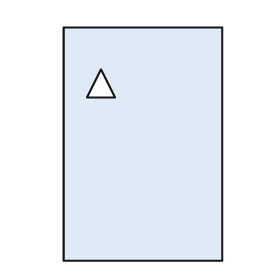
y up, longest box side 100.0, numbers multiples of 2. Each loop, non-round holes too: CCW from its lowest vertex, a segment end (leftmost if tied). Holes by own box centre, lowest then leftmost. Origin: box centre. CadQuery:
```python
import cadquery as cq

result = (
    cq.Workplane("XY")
    .moveTo(-34.0, -50.0)
    .lineTo(34.0, -50.0)
    .lineTo(34.0, 50.0)
    .lineTo(-34.0, 50.0)
    .close()
    .moveTo(-24.0, 20.0)
    .lineTo(-12.0, 20.0)
    .lineTo(-18.0, 32.0)
    .close()
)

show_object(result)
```